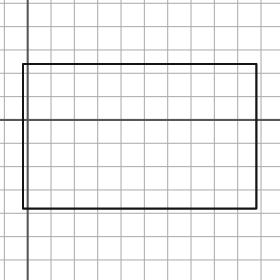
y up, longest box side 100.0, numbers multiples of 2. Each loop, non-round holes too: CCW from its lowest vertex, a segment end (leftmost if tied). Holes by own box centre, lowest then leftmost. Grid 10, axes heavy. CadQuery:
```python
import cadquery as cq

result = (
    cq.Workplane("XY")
    .moveTo(-2.0, -38.0)
    .lineTo(98.0, -38.0)
    .lineTo(98.0, 24.0)
    .lineTo(-2.0, 24.0)
    .close()
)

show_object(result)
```